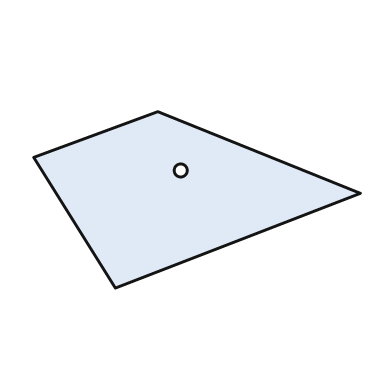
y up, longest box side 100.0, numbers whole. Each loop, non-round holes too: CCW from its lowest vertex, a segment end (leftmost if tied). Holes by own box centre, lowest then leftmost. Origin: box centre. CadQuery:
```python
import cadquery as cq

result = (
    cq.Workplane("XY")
    .moveTo(-25.0, -27.0)
    .lineTo(50.0, 2.0)
    .lineTo(-12.0, 27.0)
    .lineTo(-50.0, 13.0)
    .close()
    .moveTo(-5.0, 9.0)
    .circle(2.0)
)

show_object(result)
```